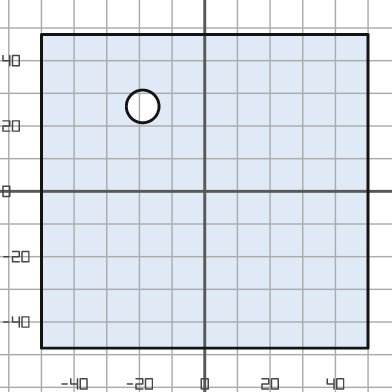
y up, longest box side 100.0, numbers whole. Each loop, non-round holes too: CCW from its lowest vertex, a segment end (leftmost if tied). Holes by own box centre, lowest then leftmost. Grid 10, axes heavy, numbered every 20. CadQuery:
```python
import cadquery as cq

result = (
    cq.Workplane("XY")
    .moveTo(-50.0, -48.0)
    .lineTo(50.0, -48.0)
    .lineTo(50.0, 48.0)
    .lineTo(-50.0, 48.0)
    .close()
    .moveTo(-19.0, 26.0)
    .circle(5.0)
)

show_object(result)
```